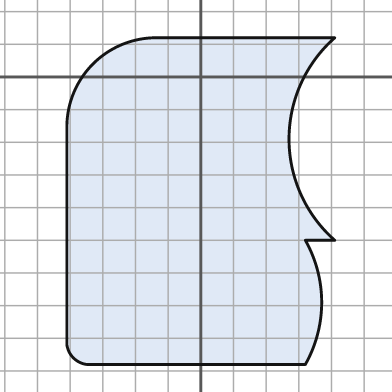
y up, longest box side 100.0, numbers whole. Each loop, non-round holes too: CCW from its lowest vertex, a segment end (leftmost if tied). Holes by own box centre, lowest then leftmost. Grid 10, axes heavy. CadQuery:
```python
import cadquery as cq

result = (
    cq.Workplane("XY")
    .moveTo(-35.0, -88.0)
    .lineTo(32.0, -88.0)
    .threePointArc((37.0, -69.0), (32.0, -50.0))
    .lineTo(41.0, -50.0)
    .threePointArc((27.0, -19.0), (41.0, 12.0))
    .lineTo(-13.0, 12.0)
    .threePointArc((-33.0, 4.0), (-41.0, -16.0))
    .lineTo(-41.0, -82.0)
    .threePointArc((-39.0, -86.0), (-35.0, -88.0))
    .close()
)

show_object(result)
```